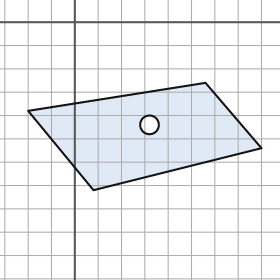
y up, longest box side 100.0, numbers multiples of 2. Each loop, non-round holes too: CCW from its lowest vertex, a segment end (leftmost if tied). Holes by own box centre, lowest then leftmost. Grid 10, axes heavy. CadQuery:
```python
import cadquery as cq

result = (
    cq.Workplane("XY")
    .moveTo(8.0, -72.0)
    .lineTo(80.0, -54.0)
    .lineTo(56.0, -26.0)
    .lineTo(-20.0, -38.0)
    .close()
    .moveTo(32.0, -44.0)
    .circle(4.0)
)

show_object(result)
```